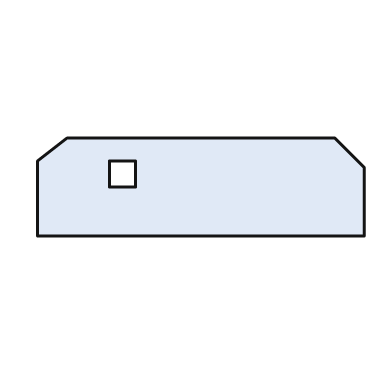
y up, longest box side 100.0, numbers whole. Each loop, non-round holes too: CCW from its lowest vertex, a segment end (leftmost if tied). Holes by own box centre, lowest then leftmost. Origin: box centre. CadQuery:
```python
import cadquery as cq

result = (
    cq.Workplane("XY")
    .moveTo(-50.0, -15.0)
    .lineTo(50.0, -15.0)
    .lineTo(50.0, 6.0)
    .lineTo(41.0, 15.0)
    .lineTo(-41.0, 15.0)
    .lineTo(-50.0, 8.0)
    .close()
    .moveTo(-28.0, 0.0)
    .lineTo(-20.0, 0.0)
    .lineTo(-20.0, 8.0)
    .lineTo(-28.0, 8.0)
    .close()
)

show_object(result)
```